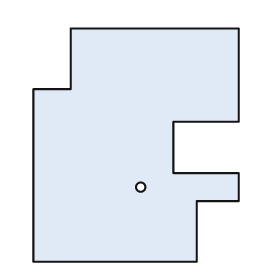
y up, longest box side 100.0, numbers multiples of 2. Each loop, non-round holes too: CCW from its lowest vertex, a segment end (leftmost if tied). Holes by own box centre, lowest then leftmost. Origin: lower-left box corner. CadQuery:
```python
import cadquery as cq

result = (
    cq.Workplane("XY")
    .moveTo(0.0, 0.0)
    .lineTo(70.0, 0.0)
    .lineTo(70.0, 26.0)
    .lineTo(88.0, 26.0)
    .lineTo(88.0, 38.0)
    .lineTo(60.0, 38.0)
    .lineTo(60.0, 60.0)
    .lineTo(88.0, 60.0)
    .lineTo(88.0, 100.0)
    .lineTo(16.0, 100.0)
    .lineTo(16.0, 74.0)
    .lineTo(0.0, 74.0)
    .close()
    .moveTo(46.0, 32.0)
    .circle(2.0)
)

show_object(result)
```